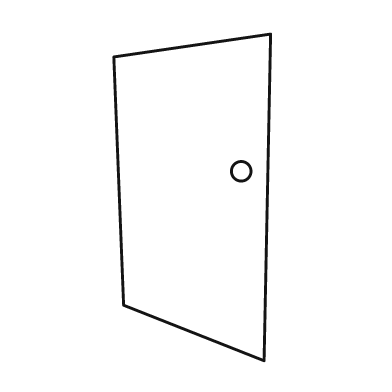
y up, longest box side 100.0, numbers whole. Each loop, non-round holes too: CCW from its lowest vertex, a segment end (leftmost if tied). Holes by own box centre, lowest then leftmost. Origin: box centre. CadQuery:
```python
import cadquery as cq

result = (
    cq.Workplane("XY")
    .moveTo(22.0, -50.0)
    .lineTo(24.0, 50.0)
    .lineTo(-24.0, 43.0)
    .lineTo(-21.0, -33.0)
    .close()
    .moveTo(15.0, 8.0)
    .circle(3.0)
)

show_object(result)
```